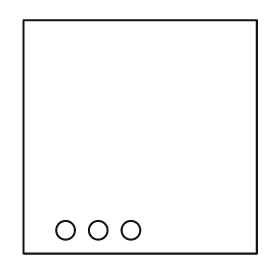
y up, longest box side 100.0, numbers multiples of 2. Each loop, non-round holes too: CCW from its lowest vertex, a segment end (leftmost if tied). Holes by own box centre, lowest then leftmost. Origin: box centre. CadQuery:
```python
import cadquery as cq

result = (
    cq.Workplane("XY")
    .moveTo(-50.0, -50.0)
    .lineTo(50.0, -50.0)
    .lineTo(50.0, 50.0)
    .lineTo(-50.0, 50.0)
    .close()
    .moveTo(-32.0, -40.0)
    .circle(4.0)
    .moveTo(-18.0, -40.0)
    .circle(4.0)
    .moveTo(-4.0, -40.0)
    .circle(4.0)
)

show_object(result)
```